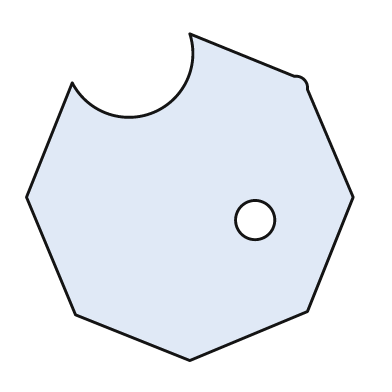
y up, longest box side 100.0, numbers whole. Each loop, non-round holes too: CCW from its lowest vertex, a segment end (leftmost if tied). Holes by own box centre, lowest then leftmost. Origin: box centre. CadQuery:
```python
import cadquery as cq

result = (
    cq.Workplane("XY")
    .moveTo(0.0, -50.0)
    .lineTo(36.0, -35.0)
    .lineTo(50.0, 0.0)
    .lineTo(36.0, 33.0)
    .threePointArc((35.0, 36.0), (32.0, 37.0))
    .lineTo(0.0, 50.0)
    .threePointArc((-11.0, 26.0), (-36.0, 35.0))
    .lineTo(-50.0, 0.0)
    .lineTo(-35.0, -36.0)
    .close()
    .moveTo(20.0, -7.0)
    .circle(6.0)
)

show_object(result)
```